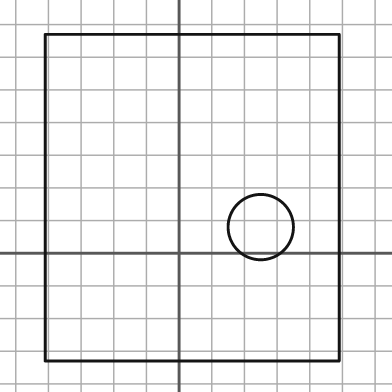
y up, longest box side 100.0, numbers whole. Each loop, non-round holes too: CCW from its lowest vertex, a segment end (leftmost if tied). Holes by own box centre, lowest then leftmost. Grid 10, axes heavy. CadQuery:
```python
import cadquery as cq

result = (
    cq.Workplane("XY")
    .moveTo(-41.0, -33.0)
    .lineTo(49.0, -33.0)
    .lineTo(49.0, 67.0)
    .lineTo(-41.0, 67.0)
    .close()
    .moveTo(25.0, 8.0)
    .circle(10.0)
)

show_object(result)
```